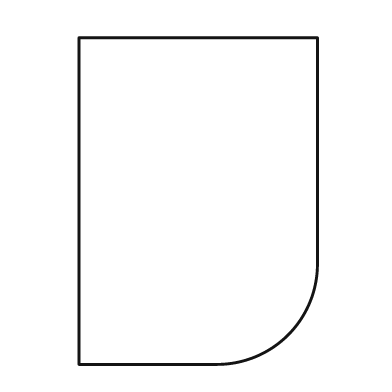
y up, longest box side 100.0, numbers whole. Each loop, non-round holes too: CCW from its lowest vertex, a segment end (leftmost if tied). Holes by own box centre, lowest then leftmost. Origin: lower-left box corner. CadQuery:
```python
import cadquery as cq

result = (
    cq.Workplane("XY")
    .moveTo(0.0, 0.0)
    .lineTo(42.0, 0.0)
    .threePointArc((64.0, 9.0), (73.0, 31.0))
    .lineTo(73.0, 100.0)
    .lineTo(0.0, 100.0)
    .close()
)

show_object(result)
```